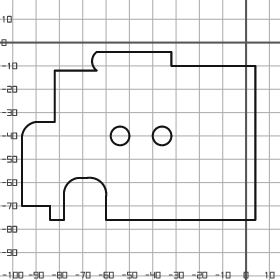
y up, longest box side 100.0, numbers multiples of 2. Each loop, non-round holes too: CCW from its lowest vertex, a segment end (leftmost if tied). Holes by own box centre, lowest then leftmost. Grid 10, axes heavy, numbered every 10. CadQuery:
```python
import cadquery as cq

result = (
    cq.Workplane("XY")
    .moveTo(-84.0, -76.0)
    .lineTo(-78.0, -76.0)
    .lineTo(-78.0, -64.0)
    .threePointArc((-76.0, -60.0), (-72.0, -58.0))
    .lineTo(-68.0, -58.0)
    .threePointArc((-62.0, -60.0), (-60.0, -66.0))
    .lineTo(-60.0, -76.0)
    .lineTo(4.0, -76.0)
    .lineTo(4.0, -10.0)
    .lineTo(-32.0, -10.0)
    .lineTo(-32.0, -4.0)
    .lineTo(-64.0, -4.0)
    .threePointArc((-66.0, -8.0), (-64.0, -12.0))
    .lineTo(-82.0, -12.0)
    .lineTo(-82.0, -34.0)
    .lineTo(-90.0, -34.0)
    .threePointArc((-94.0, -36.0), (-96.0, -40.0))
    .lineTo(-96.0, -70.0)
    .lineTo(-84.0, -70.0)
    .close()
    .moveTo(-54.0, -40.0)
    .circle(4.0)
    .moveTo(-36.0, -40.0)
    .circle(4.0)
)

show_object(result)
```